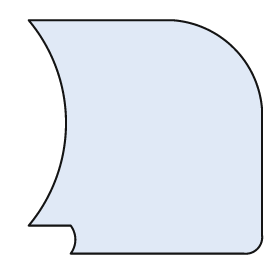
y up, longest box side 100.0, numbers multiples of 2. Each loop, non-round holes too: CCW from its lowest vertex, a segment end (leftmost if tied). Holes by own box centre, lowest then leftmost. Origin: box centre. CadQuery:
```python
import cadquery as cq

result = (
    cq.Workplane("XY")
    .moveTo(-32.0, -50.0)
    .lineTo(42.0, -50.0)
    .threePointArc((48.0, -48.0), (50.0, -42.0))
    .lineTo(50.0, 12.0)
    .threePointArc((38.0, 38.0), (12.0, 50.0))
    .lineTo(-50.0, 50.0)
    .threePointArc((-34.0, 6.0), (-50.0, -38.0))
    .lineTo(-32.0, -38.0)
    .threePointArc((-30.0, -44.0), (-32.0, -50.0))
    .close()
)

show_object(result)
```